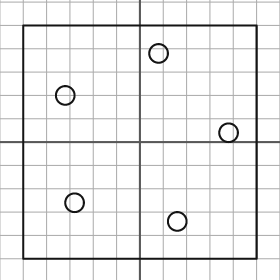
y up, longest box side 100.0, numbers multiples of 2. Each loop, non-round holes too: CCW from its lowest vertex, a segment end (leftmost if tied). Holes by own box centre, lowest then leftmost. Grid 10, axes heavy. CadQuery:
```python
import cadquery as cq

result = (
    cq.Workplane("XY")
    .moveTo(-50.0, -50.0)
    .lineTo(50.0, -50.0)
    .lineTo(50.0, 50.0)
    .lineTo(-50.0, 50.0)
    .close()
    .moveTo(16.0, -34.0)
    .circle(4.0)
    .moveTo(-28.0, -26.0)
    .circle(4.0)
    .moveTo(38.0, 4.0)
    .circle(4.0)
    .moveTo(-32.0, 20.0)
    .circle(4.0)
    .moveTo(8.0, 38.0)
    .circle(4.0)
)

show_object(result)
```